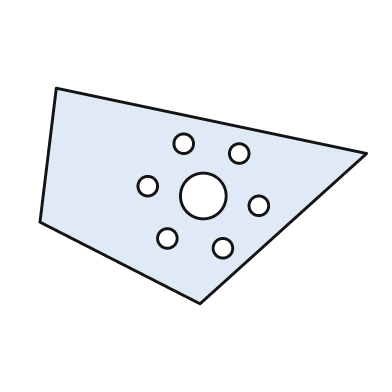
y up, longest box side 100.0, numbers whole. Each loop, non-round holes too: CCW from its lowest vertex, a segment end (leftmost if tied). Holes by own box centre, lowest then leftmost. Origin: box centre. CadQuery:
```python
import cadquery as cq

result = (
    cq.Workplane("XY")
    .moveTo(-1.0, -33.0)
    .lineTo(50.0, 13.0)
    .lineTo(-45.0, 33.0)
    .lineTo(-50.0, -8.0)
    .close()
    .moveTo(6.0, -16.0)
    .circle(3.0)
    .moveTo(-11.0, -13.0)
    .circle(3.0)
    .moveTo(17.0, -3.0)
    .circle(3.0)
    .moveTo(0.0, 0.0)
    .circle(7.0)
    .moveTo(-17.0, 3.0)
    .circle(3.0)
    .moveTo(11.0, 13.0)
    .circle(3.0)
    .moveTo(-6.0, 16.0)
    .circle(3.0)
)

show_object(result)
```